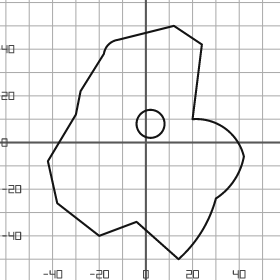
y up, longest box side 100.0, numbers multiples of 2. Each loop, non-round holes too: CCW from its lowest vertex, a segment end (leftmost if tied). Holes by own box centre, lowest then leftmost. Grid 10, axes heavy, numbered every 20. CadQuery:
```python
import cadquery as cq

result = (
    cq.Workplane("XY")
    .moveTo(14.0, -50.0)
    .threePointArc((24.0, -38.0), (30.0, -24.0))
    .threePointArc((38.0, -16.0), (42.0, -6.0))
    .threePointArc((34.0, 6.0), (20.0, 10.0))
    .lineTo(24.0, 42.0)
    .lineTo(12.0, 50.0)
    .lineTo(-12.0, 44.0)
    .threePointArc((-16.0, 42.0), (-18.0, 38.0))
    .lineTo(-28.0, 22.0)
    .lineTo(-30.0, 12.0)
    .lineTo(-42.0, -8.0)
    .lineTo(-38.0, -26.0)
    .lineTo(-20.0, -40.0)
    .lineTo(-4.0, -34.0)
    .close()
    .moveTo(2.0, 8.0)
    .circle(6.0)
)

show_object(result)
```